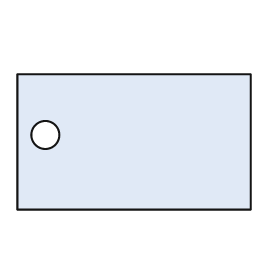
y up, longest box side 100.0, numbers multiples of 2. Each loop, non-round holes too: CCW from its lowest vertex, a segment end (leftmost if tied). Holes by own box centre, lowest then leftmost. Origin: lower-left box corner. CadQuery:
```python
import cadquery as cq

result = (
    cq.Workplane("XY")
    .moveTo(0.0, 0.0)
    .lineTo(100.0, 0.0)
    .lineTo(100.0, 58.0)
    .lineTo(0.0, 58.0)
    .close()
    .moveTo(12.0, 32.0)
    .circle(6.0)
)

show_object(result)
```